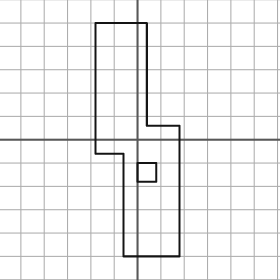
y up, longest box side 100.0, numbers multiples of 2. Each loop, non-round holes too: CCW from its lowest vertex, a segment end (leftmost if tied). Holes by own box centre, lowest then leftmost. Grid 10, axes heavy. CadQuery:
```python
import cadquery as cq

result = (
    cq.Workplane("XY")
    .moveTo(-6.0, -50.0)
    .lineTo(18.0, -50.0)
    .lineTo(18.0, 6.0)
    .lineTo(4.0, 6.0)
    .lineTo(4.0, 50.0)
    .lineTo(-18.0, 50.0)
    .lineTo(-18.0, -6.0)
    .lineTo(-6.0, -6.0)
    .close()
    .moveTo(0.0, -18.0)
    .lineTo(8.0, -18.0)
    .lineTo(8.0, -10.0)
    .lineTo(0.0, -10.0)
    .close()
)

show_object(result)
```